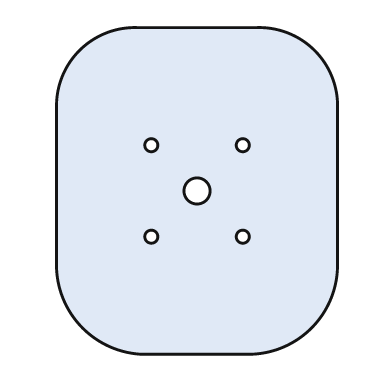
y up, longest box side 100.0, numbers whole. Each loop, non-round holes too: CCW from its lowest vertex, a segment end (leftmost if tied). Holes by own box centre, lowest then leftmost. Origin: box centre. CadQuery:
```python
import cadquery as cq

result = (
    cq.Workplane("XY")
    .moveTo(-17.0, -50.0)
    .lineTo(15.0, -50.0)
    .threePointArc((35.0, -42.0), (43.0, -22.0))
    .lineTo(43.0, 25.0)
    .threePointArc((36.0, 43.0), (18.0, 50.0))
    .lineTo(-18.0, 50.0)
    .threePointArc((-36.0, 43.0), (-43.0, 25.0))
    .lineTo(-43.0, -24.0)
    .threePointArc((-35.0, -42.0), (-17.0, -50.0))
    .close()
    .moveTo(-14.0, -14.0)
    .circle(2.0)
    .moveTo(14.0, -14.0)
    .circle(2.0)
    .moveTo(0.0, 0.0)
    .circle(4.0)
    .moveTo(-14.0, 14.0)
    .circle(2.0)
    .moveTo(14.0, 14.0)
    .circle(2.0)
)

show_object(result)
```